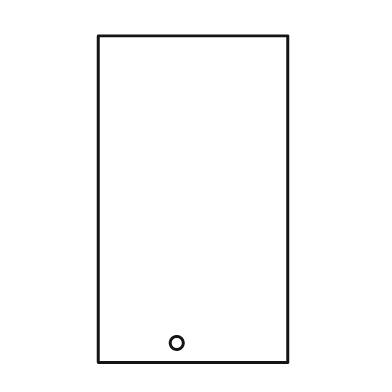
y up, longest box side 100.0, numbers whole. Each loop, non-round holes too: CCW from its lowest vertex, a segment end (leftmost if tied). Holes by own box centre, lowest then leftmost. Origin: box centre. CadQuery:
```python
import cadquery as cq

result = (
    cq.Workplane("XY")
    .moveTo(-29.0, -50.0)
    .lineTo(29.0, -50.0)
    .lineTo(29.0, 50.0)
    .lineTo(-29.0, 50.0)
    .close()
    .moveTo(-5.0, -44.0)
    .circle(2.0)
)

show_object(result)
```